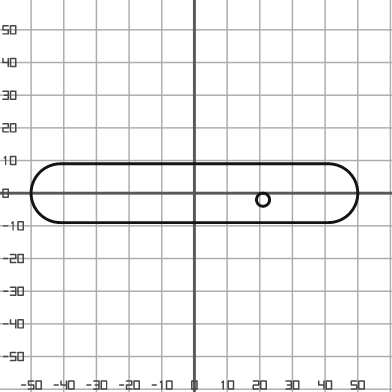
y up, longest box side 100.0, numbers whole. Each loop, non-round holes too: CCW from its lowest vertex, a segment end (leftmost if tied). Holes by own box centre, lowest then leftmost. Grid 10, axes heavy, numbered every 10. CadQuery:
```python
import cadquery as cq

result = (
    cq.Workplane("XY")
    .moveTo(-41.0, -9.0)
    .lineTo(41.0, -9.0)
    .threePointArc((50.0, 0.0), (41.0, 9.0))
    .lineTo(-41.0, 9.0)
    .threePointArc((-50.0, 0.0), (-41.0, -9.0))
    .close()
    .moveTo(21.0, -2.0)
    .circle(2.0)
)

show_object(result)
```